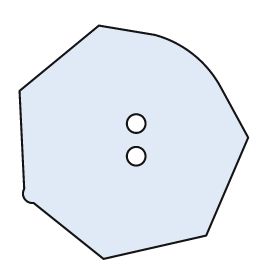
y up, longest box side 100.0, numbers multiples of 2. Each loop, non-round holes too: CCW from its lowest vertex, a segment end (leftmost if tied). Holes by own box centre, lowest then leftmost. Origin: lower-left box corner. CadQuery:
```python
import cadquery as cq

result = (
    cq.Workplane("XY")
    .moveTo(36.0, 0.0)
    .lineTo(80.0, 10.0)
    .lineTo(98.0, 52.0)
    .lineTo(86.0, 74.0)
    .threePointArc((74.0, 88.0), (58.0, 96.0))
    .lineTo(34.0, 100.0)
    .lineTo(0.0, 72.0)
    .lineTo(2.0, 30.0)
    .threePointArc((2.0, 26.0), (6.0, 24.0))
    .close()
    .moveTo(50.0, 44.0)
    .circle(4.0)
    .moveTo(50.0, 58.0)
    .circle(4.0)
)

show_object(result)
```